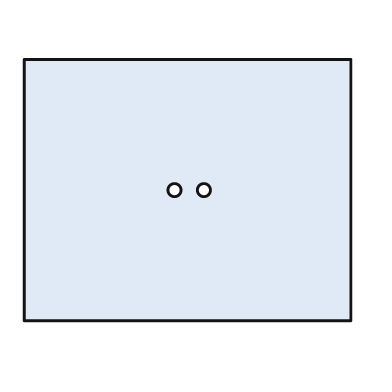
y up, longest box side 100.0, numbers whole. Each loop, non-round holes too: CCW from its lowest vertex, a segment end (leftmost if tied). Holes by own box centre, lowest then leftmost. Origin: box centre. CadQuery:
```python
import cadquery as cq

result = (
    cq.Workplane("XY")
    .moveTo(-50.0, -40.0)
    .lineTo(50.0, -40.0)
    .lineTo(50.0, 40.0)
    .lineTo(-50.0, 40.0)
    .close()
    .moveTo(-4.0, 0.0)
    .circle(2.0)
    .moveTo(5.0, 0.0)
    .circle(2.0)
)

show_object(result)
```